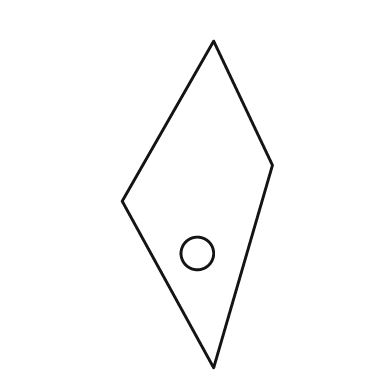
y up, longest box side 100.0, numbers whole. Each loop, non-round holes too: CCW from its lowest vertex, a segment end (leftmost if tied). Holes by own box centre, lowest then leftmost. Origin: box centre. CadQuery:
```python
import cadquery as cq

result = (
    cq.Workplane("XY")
    .moveTo(5.0, -50.0)
    .lineTo(23.0, 12.0)
    .lineTo(5.0, 50.0)
    .lineTo(-23.0, 1.0)
    .close()
    .moveTo(0.0, -15.0)
    .circle(5.0)
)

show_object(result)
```